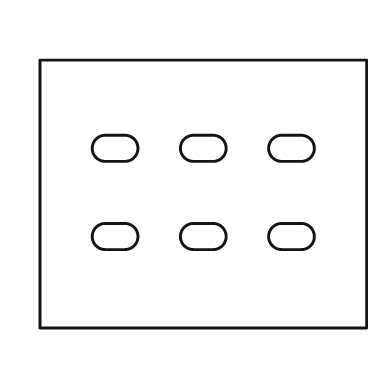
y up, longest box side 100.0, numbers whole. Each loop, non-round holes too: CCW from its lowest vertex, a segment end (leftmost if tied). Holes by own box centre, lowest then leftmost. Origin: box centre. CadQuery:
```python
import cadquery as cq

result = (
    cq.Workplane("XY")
    .moveTo(-50.0, -41.0)
    .lineTo(50.0, -41.0)
    .lineTo(50.0, 41.0)
    .lineTo(-50.0, 41.0)
    .close()
    .moveTo(-30.0, -17.0)
    .lineTo(-24.0, -17.0)
    .threePointArc((-20.0, -13.0), (-24.0, -9.0))
    .lineTo(-30.0, -9.0)
    .threePointArc((-34.0, -13.0), (-30.0, -17.0))
    .close()
    .moveTo(-3.0, -17.0)
    .lineTo(3.0, -17.0)
    .threePointArc((7.0, -13.0), (3.0, -9.0))
    .lineTo(-3.0, -9.0)
    .threePointArc((-7.0, -13.0), (-3.0, -17.0))
    .close()
    .moveTo(24.0, -17.0)
    .lineTo(30.0, -17.0)
    .threePointArc((34.0, -13.0), (30.0, -9.0))
    .lineTo(24.0, -9.0)
    .threePointArc((20.0, -13.0), (24.0, -17.0))
    .close()
    .moveTo(-30.0, 10.0)
    .lineTo(-24.0, 10.0)
    .threePointArc((-20.0, 14.0), (-24.0, 18.0))
    .lineTo(-30.0, 18.0)
    .threePointArc((-34.0, 14.0), (-30.0, 10.0))
    .close()
    .moveTo(-3.0, 10.0)
    .lineTo(3.0, 10.0)
    .threePointArc((7.0, 14.0), (3.0, 18.0))
    .lineTo(-3.0, 18.0)
    .threePointArc((-7.0, 14.0), (-3.0, 10.0))
    .close()
    .moveTo(24.0, 10.0)
    .lineTo(30.0, 10.0)
    .threePointArc((34.0, 14.0), (30.0, 18.0))
    .lineTo(24.0, 18.0)
    .threePointArc((20.0, 14.0), (24.0, 10.0))
    .close()
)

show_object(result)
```